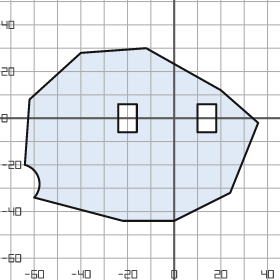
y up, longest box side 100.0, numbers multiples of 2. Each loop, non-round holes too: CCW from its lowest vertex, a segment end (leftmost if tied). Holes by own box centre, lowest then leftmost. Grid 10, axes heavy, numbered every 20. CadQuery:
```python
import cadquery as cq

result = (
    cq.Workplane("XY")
    .moveTo(-22.0, -44.0)
    .lineTo(0.0, -44.0)
    .lineTo(24.0, -32.0)
    .lineTo(36.0, -2.0)
    .lineTo(20.0, 12.0)
    .lineTo(-12.0, 30.0)
    .lineTo(-40.0, 28.0)
    .lineTo(-62.0, 8.0)
    .lineTo(-64.0, -20.0)
    .threePointArc((-58.0, -26.0), (-60.0, -34.0))
    .close()
    .moveTo(-24.0, -6.0)
    .lineTo(-16.0, -6.0)
    .lineTo(-16.0, 6.0)
    .lineTo(-24.0, 6.0)
    .close()
    .moveTo(10.0, -6.0)
    .lineTo(18.0, -6.0)
    .lineTo(18.0, 6.0)
    .lineTo(10.0, 6.0)
    .close()
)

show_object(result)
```